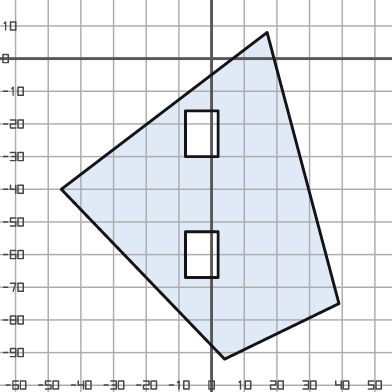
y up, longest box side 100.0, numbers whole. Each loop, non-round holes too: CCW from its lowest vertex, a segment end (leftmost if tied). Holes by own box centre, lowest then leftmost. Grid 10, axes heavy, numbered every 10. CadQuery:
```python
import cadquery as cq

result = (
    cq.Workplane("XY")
    .moveTo(4.0, -92.0)
    .lineTo(39.0, -75.0)
    .lineTo(17.0, 8.0)
    .lineTo(-46.0, -40.0)
    .close()
    .moveTo(-8.0, -67.0)
    .lineTo(2.0, -67.0)
    .lineTo(2.0, -53.0)
    .lineTo(-8.0, -53.0)
    .close()
    .moveTo(-8.0, -30.0)
    .lineTo(2.0, -30.0)
    .lineTo(2.0, -16.0)
    .lineTo(-8.0, -16.0)
    .close()
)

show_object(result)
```